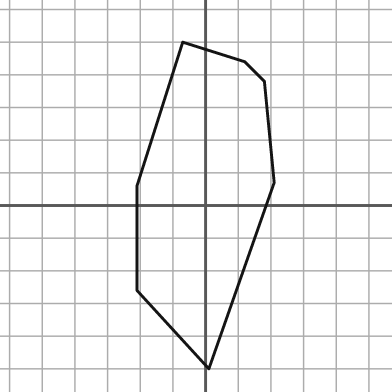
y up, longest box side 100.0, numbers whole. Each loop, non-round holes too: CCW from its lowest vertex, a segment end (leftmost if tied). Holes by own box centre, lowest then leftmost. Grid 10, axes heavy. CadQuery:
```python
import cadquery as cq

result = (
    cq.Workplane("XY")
    .moveTo(1.0, -50.0)
    .lineTo(21.0, 7.0)
    .lineTo(18.0, 38.0)
    .lineTo(12.0, 44.0)
    .lineTo(-7.0, 50.0)
    .lineTo(-21.0, 6.0)
    .lineTo(-21.0, -26.0)
    .close()
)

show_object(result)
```